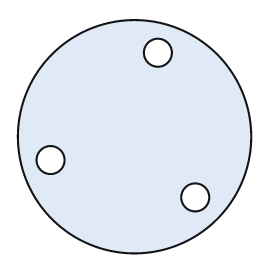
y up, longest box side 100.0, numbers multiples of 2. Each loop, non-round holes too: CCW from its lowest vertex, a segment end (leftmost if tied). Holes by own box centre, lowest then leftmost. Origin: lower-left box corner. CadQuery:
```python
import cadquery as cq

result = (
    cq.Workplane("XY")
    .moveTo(50.0, 50.0)
    .circle(50.0)
    .moveTo(76.0, 24.0)
    .circle(6.0)
    .moveTo(14.0, 40.0)
    .circle(6.0)
    .moveTo(60.0, 86.0)
    .circle(6.0)
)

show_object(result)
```